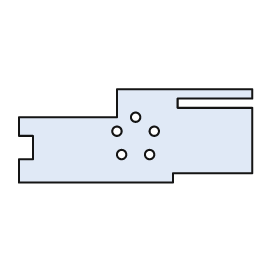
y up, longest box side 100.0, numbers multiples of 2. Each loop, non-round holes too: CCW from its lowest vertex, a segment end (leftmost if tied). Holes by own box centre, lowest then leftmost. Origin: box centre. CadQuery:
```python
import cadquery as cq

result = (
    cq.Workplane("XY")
    .moveTo(-50.0, -20.0)
    .lineTo(16.0, -20.0)
    .lineTo(16.0, -16.0)
    .lineTo(50.0, -16.0)
    .lineTo(50.0, 12.0)
    .lineTo(18.0, 12.0)
    .lineTo(18.0, 16.0)
    .lineTo(50.0, 16.0)
    .lineTo(50.0, 20.0)
    .lineTo(-8.0, 20.0)
    .lineTo(-8.0, 8.0)
    .lineTo(-50.0, 8.0)
    .lineTo(-50.0, 0.0)
    .lineTo(-44.0, 0.0)
    .lineTo(-44.0, -10.0)
    .lineTo(-50.0, -10.0)
    .close()
    .moveTo(-6.0, -8.0)
    .circle(2.0)
    .moveTo(6.0, -8.0)
    .circle(2.0)
    .moveTo(-8.0, 2.0)
    .circle(2.0)
    .moveTo(8.0, 2.0)
    .circle(2.0)
    .moveTo(0.0, 8.0)
    .circle(2.0)
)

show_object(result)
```